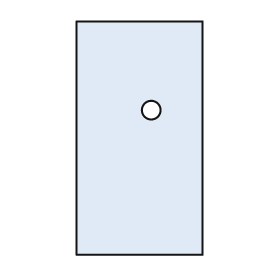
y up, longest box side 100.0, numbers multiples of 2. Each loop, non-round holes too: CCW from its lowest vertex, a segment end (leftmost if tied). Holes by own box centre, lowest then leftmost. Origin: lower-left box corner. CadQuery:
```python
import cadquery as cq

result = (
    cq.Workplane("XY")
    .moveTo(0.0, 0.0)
    .lineTo(54.0, 0.0)
    .lineTo(54.0, 100.0)
    .lineTo(0.0, 100.0)
    .close()
    .moveTo(32.0, 62.0)
    .circle(4.0)
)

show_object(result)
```